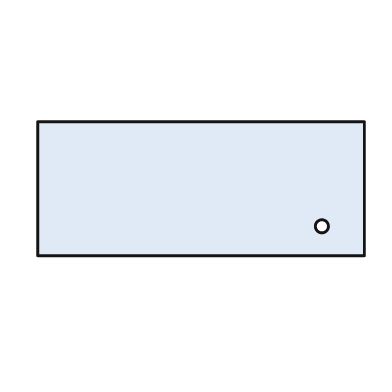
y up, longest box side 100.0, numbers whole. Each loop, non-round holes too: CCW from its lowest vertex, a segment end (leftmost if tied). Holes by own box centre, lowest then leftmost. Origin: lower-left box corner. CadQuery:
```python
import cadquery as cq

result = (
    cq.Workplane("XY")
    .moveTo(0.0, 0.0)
    .lineTo(100.0, 0.0)
    .lineTo(100.0, 41.0)
    .lineTo(0.0, 41.0)
    .close()
    .moveTo(87.0, 9.0)
    .circle(2.0)
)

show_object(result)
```